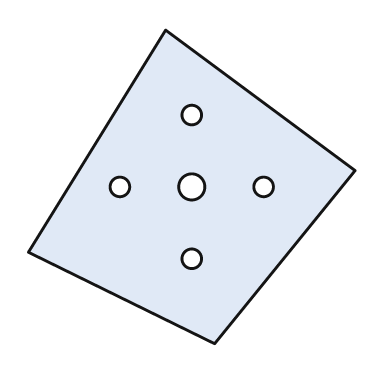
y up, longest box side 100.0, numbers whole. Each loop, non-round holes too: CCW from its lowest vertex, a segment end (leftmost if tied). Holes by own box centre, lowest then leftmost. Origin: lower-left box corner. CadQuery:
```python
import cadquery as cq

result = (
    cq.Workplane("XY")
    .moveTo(57.0, 0.0)
    .lineTo(100.0, 53.0)
    .lineTo(42.0, 96.0)
    .lineTo(0.0, 28.0)
    .close()
    .moveTo(50.0, 26.0)
    .circle(3.0)
    .moveTo(28.0, 48.0)
    .circle(3.0)
    .moveTo(50.0, 48.0)
    .circle(4.0)
    .moveTo(72.0, 48.0)
    .circle(3.0)
    .moveTo(50.0, 70.0)
    .circle(3.0)
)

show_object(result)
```